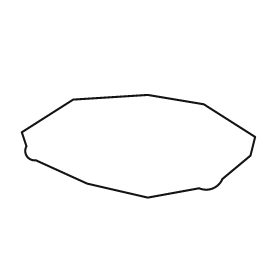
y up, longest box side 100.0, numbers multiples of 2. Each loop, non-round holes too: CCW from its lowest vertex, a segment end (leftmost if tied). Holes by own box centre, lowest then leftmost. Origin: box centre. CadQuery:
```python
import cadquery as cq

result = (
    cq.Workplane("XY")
    .moveTo(4.0, -22.0)
    .lineTo(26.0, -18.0)
    .threePointArc((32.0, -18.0), (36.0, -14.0))
    .lineTo(48.0, -4.0)
    .lineTo(50.0, 4.0)
    .lineTo(28.0, 18.0)
    .lineTo(4.0, 22.0)
    .lineTo(-28.0, 20.0)
    .lineTo(-50.0, 6.0)
    .lineTo(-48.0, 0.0)
    .threePointArc((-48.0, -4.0), (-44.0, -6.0))
    .lineTo(-22.0, -16.0)
    .close()
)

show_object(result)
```